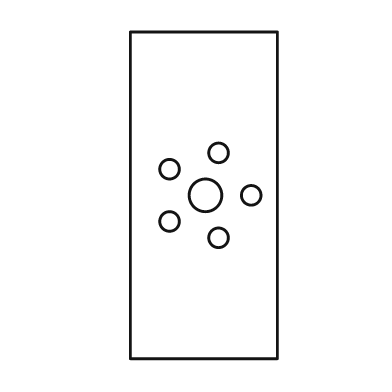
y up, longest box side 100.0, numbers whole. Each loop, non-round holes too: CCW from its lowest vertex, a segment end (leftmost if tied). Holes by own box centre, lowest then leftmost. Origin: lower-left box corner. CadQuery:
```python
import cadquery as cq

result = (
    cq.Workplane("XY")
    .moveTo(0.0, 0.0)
    .lineTo(45.0, 0.0)
    .lineTo(45.0, 100.0)
    .lineTo(0.0, 100.0)
    .close()
    .moveTo(27.0, 37.0)
    .circle(3.0)
    .moveTo(12.0, 42.0)
    .circle(3.0)
    .moveTo(23.0, 50.0)
    .circle(5.0)
    .moveTo(37.0, 50.0)
    .circle(3.0)
    .moveTo(12.0, 58.0)
    .circle(3.0)
    .moveTo(27.0, 63.0)
    .circle(3.0)
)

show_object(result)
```